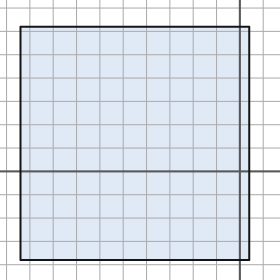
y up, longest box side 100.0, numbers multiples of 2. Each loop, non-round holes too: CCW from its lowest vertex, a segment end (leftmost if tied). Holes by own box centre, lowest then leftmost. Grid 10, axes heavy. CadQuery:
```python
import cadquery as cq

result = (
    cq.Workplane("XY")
    .moveTo(-94.0, -38.0)
    .lineTo(4.0, -38.0)
    .lineTo(4.0, 62.0)
    .lineTo(-94.0, 62.0)
    .close()
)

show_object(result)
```